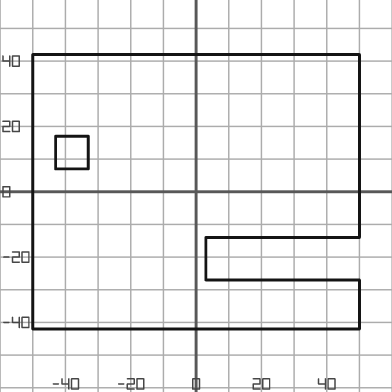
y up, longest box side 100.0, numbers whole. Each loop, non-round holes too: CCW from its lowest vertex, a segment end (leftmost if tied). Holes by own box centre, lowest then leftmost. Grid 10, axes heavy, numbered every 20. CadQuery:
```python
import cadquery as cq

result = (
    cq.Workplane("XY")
    .moveTo(-50.0, -42.0)
    .lineTo(50.0, -42.0)
    .lineTo(50.0, -27.0)
    .lineTo(3.0, -27.0)
    .lineTo(3.0, -14.0)
    .lineTo(50.0, -14.0)
    .lineTo(50.0, 42.0)
    .lineTo(-50.0, 42.0)
    .close()
    .moveTo(-43.0, 7.0)
    .lineTo(-33.0, 7.0)
    .lineTo(-33.0, 17.0)
    .lineTo(-43.0, 17.0)
    .close()
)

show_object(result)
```